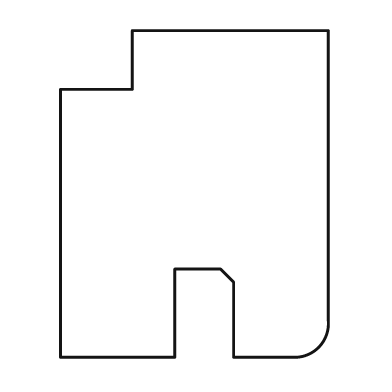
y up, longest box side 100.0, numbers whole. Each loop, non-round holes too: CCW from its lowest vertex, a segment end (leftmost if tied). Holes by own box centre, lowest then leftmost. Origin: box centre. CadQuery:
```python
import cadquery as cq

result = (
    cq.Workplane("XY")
    .moveTo(-41.0, -50.0)
    .lineTo(-6.0, -50.0)
    .lineTo(-6.0, -23.0)
    .lineTo(8.0, -23.0)
    .lineTo(12.0, -27.0)
    .lineTo(12.0, -50.0)
    .lineTo(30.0, -50.0)
    .threePointArc((38.0, -47.0), (41.0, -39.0))
    .lineTo(41.0, 50.0)
    .lineTo(-19.0, 50.0)
    .lineTo(-19.0, 32.0)
    .lineTo(-41.0, 32.0)
    .close()
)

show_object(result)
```